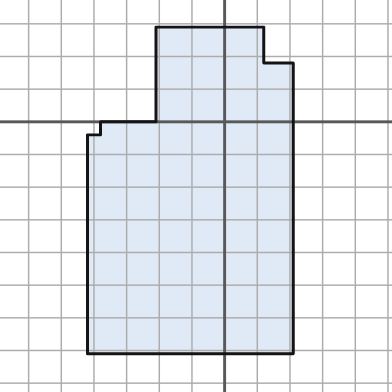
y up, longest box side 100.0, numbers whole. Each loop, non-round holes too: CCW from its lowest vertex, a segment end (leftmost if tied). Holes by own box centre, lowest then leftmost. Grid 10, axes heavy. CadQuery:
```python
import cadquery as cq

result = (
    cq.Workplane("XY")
    .moveTo(-42.0, -71.0)
    .lineTo(21.0, -71.0)
    .lineTo(21.0, 18.0)
    .lineTo(12.0, 18.0)
    .lineTo(12.0, 29.0)
    .lineTo(-21.0, 29.0)
    .lineTo(-21.0, 0.0)
    .lineTo(-38.0, 0.0)
    .lineTo(-38.0, -4.0)
    .lineTo(-42.0, -4.0)
    .close()
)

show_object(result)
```